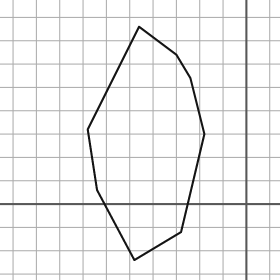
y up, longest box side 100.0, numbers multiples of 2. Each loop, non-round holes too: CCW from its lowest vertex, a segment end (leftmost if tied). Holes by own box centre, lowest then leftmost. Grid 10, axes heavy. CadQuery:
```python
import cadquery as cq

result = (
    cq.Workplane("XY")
    .moveTo(-48.0, -24.0)
    .lineTo(-28.0, -12.0)
    .lineTo(-18.0, 30.0)
    .lineTo(-24.0, 54.0)
    .lineTo(-30.0, 64.0)
    .lineTo(-46.0, 76.0)
    .lineTo(-68.0, 32.0)
    .lineTo(-64.0, 6.0)
    .close()
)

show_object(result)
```